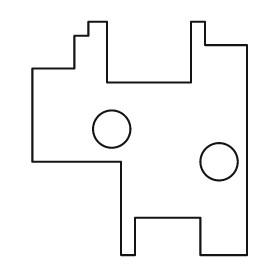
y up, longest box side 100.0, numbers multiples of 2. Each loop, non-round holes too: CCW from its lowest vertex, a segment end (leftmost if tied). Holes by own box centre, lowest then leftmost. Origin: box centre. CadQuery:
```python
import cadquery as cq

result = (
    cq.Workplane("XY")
    .moveTo(-8.0, -50.0)
    .lineTo(-2.0, -50.0)
    .lineTo(-2.0, -34.0)
    .lineTo(26.0, -34.0)
    .lineTo(26.0, -50.0)
    .lineTo(46.0, -50.0)
    .lineTo(46.0, 40.0)
    .lineTo(28.0, 40.0)
    .lineTo(28.0, 50.0)
    .lineTo(22.0, 50.0)
    .lineTo(22.0, 24.0)
    .lineTo(-14.0, 24.0)
    .lineTo(-14.0, 50.0)
    .lineTo(-22.0, 50.0)
    .lineTo(-22.0, 44.0)
    .lineTo(-28.0, 44.0)
    .lineTo(-28.0, 30.0)
    .lineTo(-46.0, 30.0)
    .lineTo(-46.0, -10.0)
    .lineTo(-8.0, -10.0)
    .close()
    .moveTo(34.0, -10.0)
    .circle(8.0)
    .moveTo(-12.0, 4.0)
    .circle(8.0)
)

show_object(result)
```